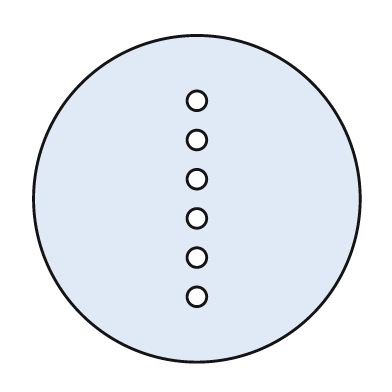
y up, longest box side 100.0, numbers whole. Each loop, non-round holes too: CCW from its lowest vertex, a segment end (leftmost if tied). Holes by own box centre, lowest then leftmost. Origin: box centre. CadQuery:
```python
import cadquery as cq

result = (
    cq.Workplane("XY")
    .moveTo(0.0, 0.0)
    .circle(50.0)
    .moveTo(0.0, -30.0)
    .circle(3.0)
    .moveTo(0.0, -18.0)
    .circle(3.0)
    .moveTo(0.0, -6.0)
    .circle(3.0)
    .moveTo(0.0, 6.0)
    .circle(3.0)
    .moveTo(0.0, 18.0)
    .circle(3.0)
    .moveTo(0.0, 30.0)
    .circle(3.0)
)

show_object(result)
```